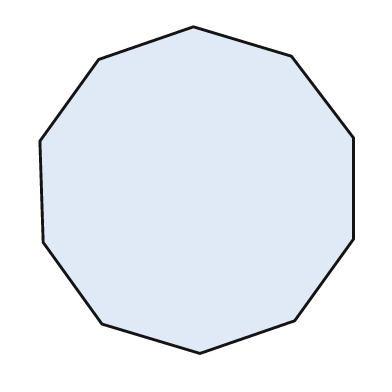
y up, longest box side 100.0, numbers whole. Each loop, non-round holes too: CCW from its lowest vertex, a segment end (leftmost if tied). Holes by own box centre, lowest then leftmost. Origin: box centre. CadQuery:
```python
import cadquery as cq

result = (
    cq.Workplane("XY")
    .moveTo(1.0, -50.0)
    .lineTo(30.0, -40.0)
    .lineTo(48.0, -15.0)
    .lineTo(48.0, 16.0)
    .lineTo(29.0, 41.0)
    .lineTo(-1.0, 50.0)
    .lineTo(-30.0, 40.0)
    .lineTo(-48.0, 15.0)
    .lineTo(-47.0, -16.0)
    .lineTo(-29.0, -41.0)
    .close()
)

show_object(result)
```